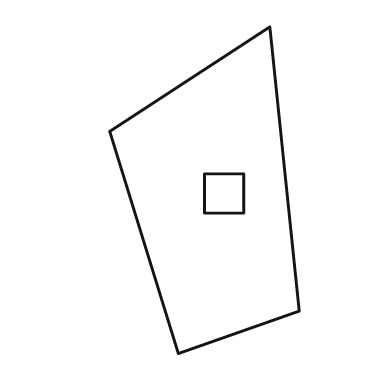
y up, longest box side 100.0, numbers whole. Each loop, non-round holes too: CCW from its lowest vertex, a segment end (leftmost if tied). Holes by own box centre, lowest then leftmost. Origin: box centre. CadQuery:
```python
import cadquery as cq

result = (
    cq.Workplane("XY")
    .moveTo(-8.0, -50.0)
    .lineTo(29.0, -37.0)
    .lineTo(20.0, 50.0)
    .lineTo(-29.0, 18.0)
    .close()
    .moveTo(0.0, -7.0)
    .lineTo(12.0, -7.0)
    .lineTo(12.0, 5.0)
    .lineTo(0.0, 5.0)
    .close()
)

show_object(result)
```